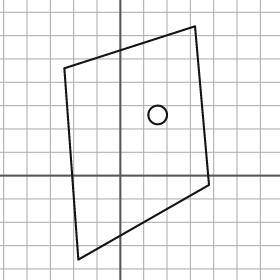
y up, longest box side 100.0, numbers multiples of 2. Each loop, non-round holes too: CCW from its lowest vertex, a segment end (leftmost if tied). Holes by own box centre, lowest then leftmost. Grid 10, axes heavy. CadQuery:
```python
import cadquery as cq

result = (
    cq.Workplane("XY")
    .moveTo(-18.0, -36.0)
    .lineTo(38.0, -4.0)
    .lineTo(32.0, 64.0)
    .lineTo(-24.0, 46.0)
    .close()
    .moveTo(16.0, 26.0)
    .circle(4.0)
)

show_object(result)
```